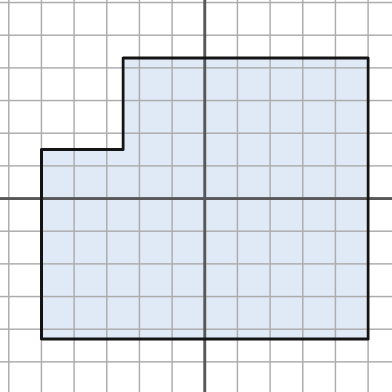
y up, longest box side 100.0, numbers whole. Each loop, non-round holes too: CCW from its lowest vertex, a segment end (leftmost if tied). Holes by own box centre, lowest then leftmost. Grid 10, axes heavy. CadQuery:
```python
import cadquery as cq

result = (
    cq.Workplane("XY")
    .moveTo(-50.0, -43.0)
    .lineTo(50.0, -43.0)
    .lineTo(50.0, 43.0)
    .lineTo(-25.0, 43.0)
    .lineTo(-25.0, 15.0)
    .lineTo(-50.0, 15.0)
    .close()
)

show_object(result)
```